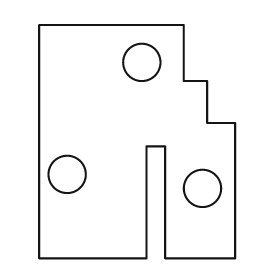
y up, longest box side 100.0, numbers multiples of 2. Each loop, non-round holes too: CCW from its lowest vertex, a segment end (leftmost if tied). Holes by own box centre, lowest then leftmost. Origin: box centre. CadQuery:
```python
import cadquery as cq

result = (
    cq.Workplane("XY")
    .moveTo(-42.0, -50.0)
    .lineTo(4.0, -50.0)
    .lineTo(4.0, -2.0)
    .lineTo(12.0, -2.0)
    .lineTo(12.0, -50.0)
    .lineTo(42.0, -50.0)
    .lineTo(42.0, 8.0)
    .lineTo(30.0, 8.0)
    .lineTo(30.0, 26.0)
    .lineTo(20.0, 26.0)
    .lineTo(20.0, 50.0)
    .lineTo(-42.0, 50.0)
    .close()
    .moveTo(28.0, -20.0)
    .circle(8.0)
    .moveTo(-30.0, -14.0)
    .circle(8.0)
    .moveTo(2.0, 34.0)
    .circle(8.0)
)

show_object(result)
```